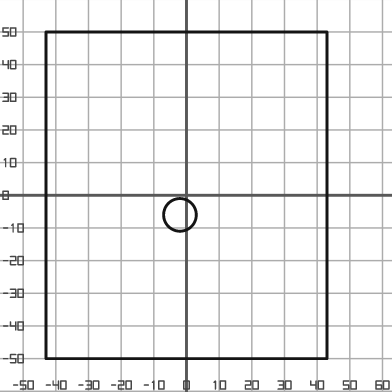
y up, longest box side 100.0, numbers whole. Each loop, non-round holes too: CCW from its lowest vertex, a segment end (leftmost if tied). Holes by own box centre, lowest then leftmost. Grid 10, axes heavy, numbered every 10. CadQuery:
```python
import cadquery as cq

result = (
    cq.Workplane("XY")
    .moveTo(-43.0, -50.0)
    .lineTo(43.0, -50.0)
    .lineTo(43.0, 50.0)
    .lineTo(-43.0, 50.0)
    .close()
    .moveTo(-2.0, -6.0)
    .circle(5.0)
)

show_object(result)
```